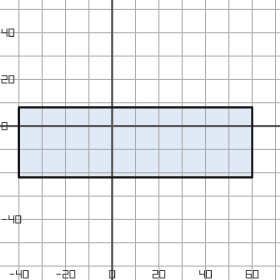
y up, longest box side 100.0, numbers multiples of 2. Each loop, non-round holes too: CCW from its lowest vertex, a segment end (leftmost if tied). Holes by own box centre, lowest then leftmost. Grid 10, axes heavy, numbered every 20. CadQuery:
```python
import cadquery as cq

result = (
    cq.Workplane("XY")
    .moveTo(-40.0, -22.0)
    .lineTo(60.0, -22.0)
    .lineTo(60.0, 8.0)
    .lineTo(-40.0, 8.0)
    .close()
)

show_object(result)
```